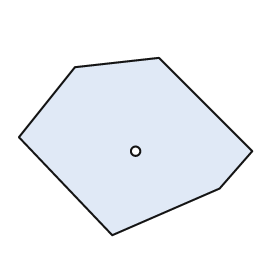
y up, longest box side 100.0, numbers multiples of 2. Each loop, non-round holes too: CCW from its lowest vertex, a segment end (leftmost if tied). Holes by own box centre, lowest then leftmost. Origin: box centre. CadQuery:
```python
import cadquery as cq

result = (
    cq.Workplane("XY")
    .moveTo(-10.0, -38.0)
    .lineTo(36.0, -18.0)
    .lineTo(50.0, -2.0)
    .lineTo(10.0, 38.0)
    .lineTo(-26.0, 34.0)
    .lineTo(-50.0, 4.0)
    .close()
    .moveTo(0.0, -2.0)
    .circle(2.0)
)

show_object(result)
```